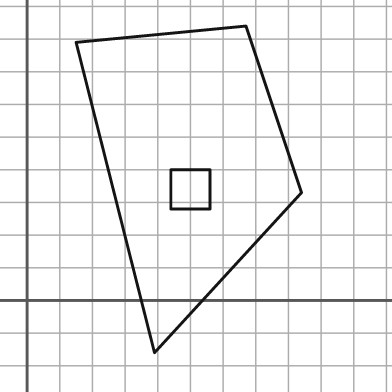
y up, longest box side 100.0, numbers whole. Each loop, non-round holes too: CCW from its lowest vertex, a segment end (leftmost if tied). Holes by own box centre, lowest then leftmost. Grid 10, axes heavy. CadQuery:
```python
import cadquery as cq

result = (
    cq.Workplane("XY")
    .moveTo(39.0, -16.0)
    .lineTo(84.0, 33.0)
    .lineTo(67.0, 84.0)
    .lineTo(15.0, 79.0)
    .close()
    .moveTo(44.0, 28.0)
    .lineTo(56.0, 28.0)
    .lineTo(56.0, 40.0)
    .lineTo(44.0, 40.0)
    .close()
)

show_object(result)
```